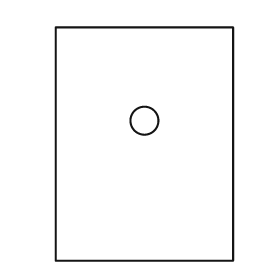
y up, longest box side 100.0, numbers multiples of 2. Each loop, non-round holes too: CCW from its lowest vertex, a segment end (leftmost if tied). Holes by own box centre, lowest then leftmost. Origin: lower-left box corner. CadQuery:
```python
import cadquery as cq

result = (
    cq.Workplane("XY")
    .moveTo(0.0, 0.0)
    .lineTo(76.0, 0.0)
    .lineTo(76.0, 100.0)
    .lineTo(0.0, 100.0)
    .close()
    .moveTo(38.0, 60.0)
    .circle(6.0)
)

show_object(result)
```